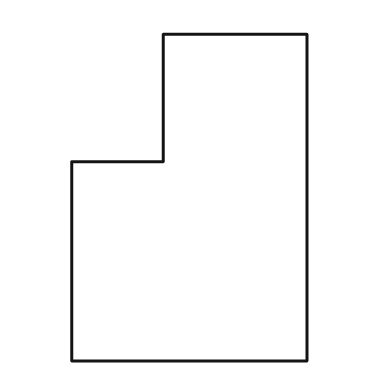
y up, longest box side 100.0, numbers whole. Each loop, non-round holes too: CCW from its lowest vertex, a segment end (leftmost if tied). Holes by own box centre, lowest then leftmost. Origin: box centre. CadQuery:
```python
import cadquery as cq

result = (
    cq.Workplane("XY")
    .moveTo(-36.0, -50.0)
    .lineTo(36.0, -50.0)
    .lineTo(36.0, 50.0)
    .lineTo(-8.0, 50.0)
    .lineTo(-8.0, 11.0)
    .lineTo(-36.0, 11.0)
    .close()
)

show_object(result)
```